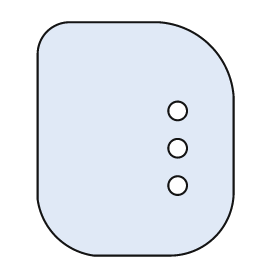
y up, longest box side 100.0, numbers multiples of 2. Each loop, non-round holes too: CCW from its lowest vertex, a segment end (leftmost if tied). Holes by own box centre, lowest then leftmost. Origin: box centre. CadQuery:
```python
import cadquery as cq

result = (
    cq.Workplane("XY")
    .moveTo(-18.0, -50.0)
    .lineTo(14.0, -50.0)
    .threePointArc((34.0, -42.0), (42.0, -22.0))
    .lineTo(42.0, 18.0)
    .threePointArc((32.0, 40.0), (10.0, 50.0))
    .lineTo(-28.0, 50.0)
    .threePointArc((-38.0, 46.0), (-42.0, 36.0))
    .lineTo(-42.0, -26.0)
    .threePointArc((-34.0, -42.0), (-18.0, -50.0))
    .close()
    .moveTo(18.0, -20.0)
    .circle(4.0)
    .moveTo(18.0, -4.0)
    .circle(4.0)
    .moveTo(18.0, 12.0)
    .circle(4.0)
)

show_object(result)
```